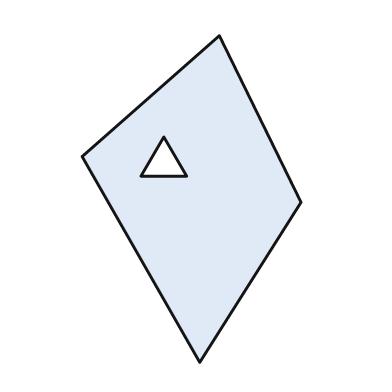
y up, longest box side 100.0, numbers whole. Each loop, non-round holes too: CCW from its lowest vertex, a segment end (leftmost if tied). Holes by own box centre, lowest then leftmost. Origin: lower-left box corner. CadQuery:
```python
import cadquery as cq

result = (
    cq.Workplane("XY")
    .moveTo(36.0, 0.0)
    .lineTo(67.0, 49.0)
    .lineTo(42.0, 100.0)
    .lineTo(0.0, 63.0)
    .close()
    .moveTo(18.0, 57.0)
    .lineTo(32.0, 57.0)
    .lineTo(25.0, 69.0)
    .close()
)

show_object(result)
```